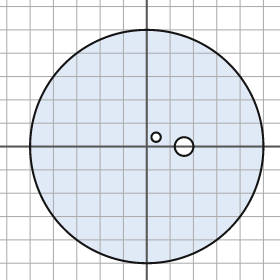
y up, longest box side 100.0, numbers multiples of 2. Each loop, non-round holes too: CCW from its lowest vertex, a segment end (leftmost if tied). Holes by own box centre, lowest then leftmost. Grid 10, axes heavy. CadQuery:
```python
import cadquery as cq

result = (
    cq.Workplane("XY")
    .moveTo(0.0, 0.0)
    .circle(50.0)
    .moveTo(16.0, 0.0)
    .circle(4.0)
    .moveTo(4.0, 4.0)
    .circle(2.0)
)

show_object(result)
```